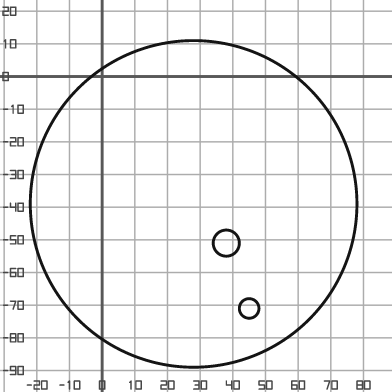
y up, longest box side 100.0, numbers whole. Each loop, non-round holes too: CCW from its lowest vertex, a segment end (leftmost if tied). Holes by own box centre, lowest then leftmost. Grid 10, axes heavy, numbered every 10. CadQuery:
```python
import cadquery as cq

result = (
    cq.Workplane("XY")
    .moveTo(28.0, -39.0)
    .circle(50.0)
    .moveTo(45.0, -71.0)
    .circle(3.0)
    .moveTo(38.0, -51.0)
    .circle(4.0)
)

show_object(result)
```